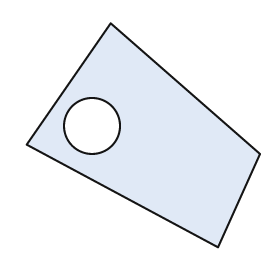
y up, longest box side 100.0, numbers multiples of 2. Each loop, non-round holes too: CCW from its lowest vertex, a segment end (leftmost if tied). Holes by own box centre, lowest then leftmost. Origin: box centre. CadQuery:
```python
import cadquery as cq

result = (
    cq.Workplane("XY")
    .moveTo(32.0, -48.0)
    .lineTo(50.0, -8.0)
    .lineTo(-14.0, 48.0)
    .lineTo(-50.0, -4.0)
    .close()
    .moveTo(-22.0, 4.0)
    .circle(12.0)
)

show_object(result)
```